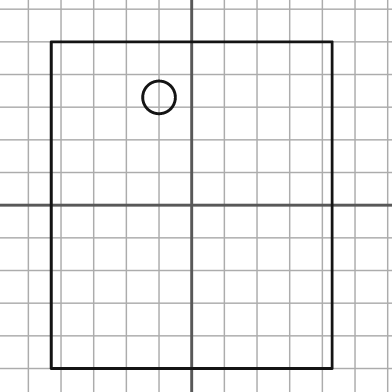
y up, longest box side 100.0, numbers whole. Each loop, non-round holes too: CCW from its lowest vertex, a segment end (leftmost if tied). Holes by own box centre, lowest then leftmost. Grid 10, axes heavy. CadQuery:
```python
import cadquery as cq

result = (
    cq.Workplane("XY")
    .moveTo(-43.0, -50.0)
    .lineTo(43.0, -50.0)
    .lineTo(43.0, 50.0)
    .lineTo(-43.0, 50.0)
    .close()
    .moveTo(-10.0, 33.0)
    .circle(5.0)
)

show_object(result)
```